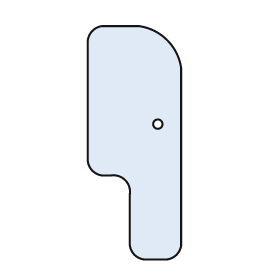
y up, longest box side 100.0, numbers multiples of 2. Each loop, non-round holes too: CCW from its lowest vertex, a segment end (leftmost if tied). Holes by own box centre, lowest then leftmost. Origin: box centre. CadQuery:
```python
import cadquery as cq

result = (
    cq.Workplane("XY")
    .moveTo(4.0, -50.0)
    .lineTo(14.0, -50.0)
    .threePointArc((18.0, -48.0), (20.0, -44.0))
    .lineTo(20.0, 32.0)
    .threePointArc((14.0, 44.0), (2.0, 50.0))
    .lineTo(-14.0, 50.0)
    .threePointArc((-18.0, 48.0), (-20.0, 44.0))
    .lineTo(-20.0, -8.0)
    .threePointArc((-18.0, -12.0), (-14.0, -14.0))
    .lineTo(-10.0, -14.0)
    .threePointArc((-4.0, -16.0), (-2.0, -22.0))
    .lineTo(-2.0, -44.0)
    .threePointArc((0.0, -48.0), (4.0, -50.0))
    .close()
    .moveTo(10.0, 8.0)
    .circle(2.0)
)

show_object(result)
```